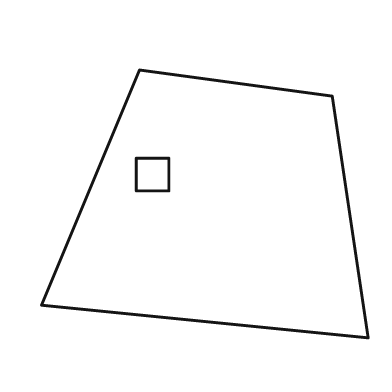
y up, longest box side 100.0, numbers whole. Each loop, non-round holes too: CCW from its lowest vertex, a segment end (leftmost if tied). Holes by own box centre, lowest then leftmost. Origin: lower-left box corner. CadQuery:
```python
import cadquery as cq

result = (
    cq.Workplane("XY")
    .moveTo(100.0, 0.0)
    .lineTo(89.0, 74.0)
    .lineTo(30.0, 82.0)
    .lineTo(0.0, 10.0)
    .close()
    .moveTo(29.0, 45.0)
    .lineTo(39.0, 45.0)
    .lineTo(39.0, 55.0)
    .lineTo(29.0, 55.0)
    .close()
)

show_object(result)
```